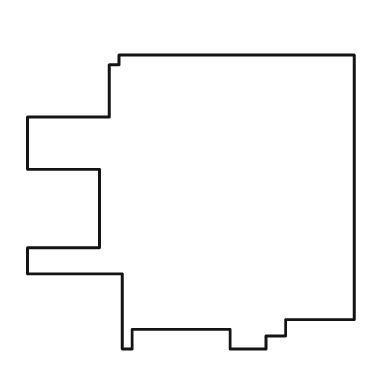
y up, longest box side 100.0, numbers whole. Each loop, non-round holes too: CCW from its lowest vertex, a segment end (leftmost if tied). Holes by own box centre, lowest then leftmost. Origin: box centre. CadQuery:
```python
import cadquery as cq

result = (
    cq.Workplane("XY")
    .moveTo(-21.0, -45.0)
    .lineTo(-18.0, -45.0)
    .lineTo(-18.0, -39.0)
    .lineTo(12.0, -39.0)
    .lineTo(12.0, -45.0)
    .lineTo(23.0, -45.0)
    .lineTo(23.0, -41.0)
    .lineTo(29.0, -41.0)
    .lineTo(29.0, -36.0)
    .lineTo(50.0, -36.0)
    .lineTo(50.0, 45.0)
    .lineTo(-22.0, 45.0)
    .lineTo(-22.0, 42.0)
    .lineTo(-25.0, 42.0)
    .lineTo(-25.0, 26.0)
    .lineTo(-50.0, 26.0)
    .lineTo(-50.0, 10.0)
    .lineTo(-28.0, 10.0)
    .lineTo(-28.0, -14.0)
    .lineTo(-50.0, -14.0)
    .lineTo(-50.0, -22.0)
    .lineTo(-21.0, -22.0)
    .close()
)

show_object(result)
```